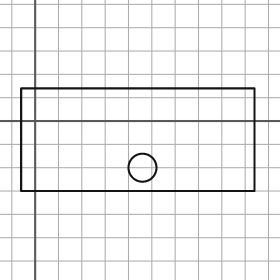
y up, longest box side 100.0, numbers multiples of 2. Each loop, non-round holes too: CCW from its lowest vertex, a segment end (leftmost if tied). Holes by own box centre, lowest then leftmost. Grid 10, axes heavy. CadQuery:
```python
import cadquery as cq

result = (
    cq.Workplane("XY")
    .moveTo(-6.0, -30.0)
    .lineTo(94.0, -30.0)
    .lineTo(94.0, 14.0)
    .lineTo(-6.0, 14.0)
    .close()
    .moveTo(46.0, -20.0)
    .circle(6.0)
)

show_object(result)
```